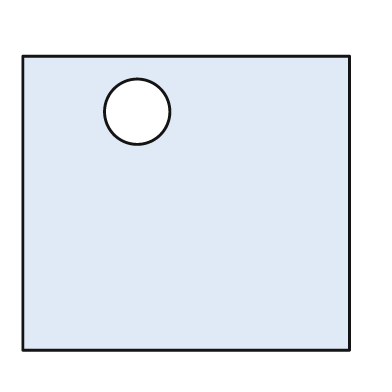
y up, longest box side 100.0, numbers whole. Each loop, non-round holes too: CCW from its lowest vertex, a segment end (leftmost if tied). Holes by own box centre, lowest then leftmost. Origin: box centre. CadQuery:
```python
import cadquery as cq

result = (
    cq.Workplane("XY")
    .moveTo(-50.0, -45.0)
    .lineTo(50.0, -45.0)
    .lineTo(50.0, 45.0)
    .lineTo(-50.0, 45.0)
    .close()
    .moveTo(-15.0, 28.0)
    .circle(10.0)
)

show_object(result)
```